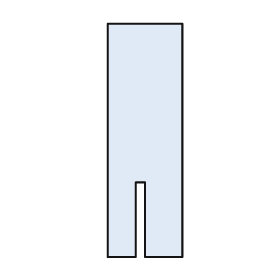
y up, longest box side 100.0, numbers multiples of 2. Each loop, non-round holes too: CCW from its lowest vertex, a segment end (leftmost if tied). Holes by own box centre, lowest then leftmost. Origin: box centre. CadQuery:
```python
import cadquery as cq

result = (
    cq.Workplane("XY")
    .moveTo(-16.0, -50.0)
    .lineTo(-4.0, -50.0)
    .lineTo(-4.0, -18.0)
    .lineTo(0.0, -18.0)
    .lineTo(0.0, -50.0)
    .lineTo(16.0, -50.0)
    .lineTo(16.0, 50.0)
    .lineTo(-16.0, 50.0)
    .close()
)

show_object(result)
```